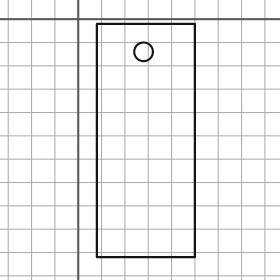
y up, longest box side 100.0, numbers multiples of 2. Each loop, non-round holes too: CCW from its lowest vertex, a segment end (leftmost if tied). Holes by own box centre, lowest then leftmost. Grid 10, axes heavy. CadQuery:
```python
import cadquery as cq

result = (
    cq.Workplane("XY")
    .moveTo(8.0, -102.0)
    .lineTo(50.0, -102.0)
    .lineTo(50.0, -2.0)
    .lineTo(8.0, -2.0)
    .close()
    .moveTo(28.0, -14.0)
    .circle(4.0)
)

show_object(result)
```